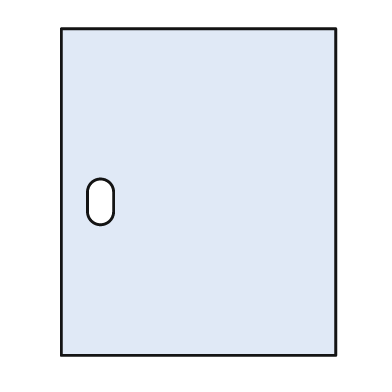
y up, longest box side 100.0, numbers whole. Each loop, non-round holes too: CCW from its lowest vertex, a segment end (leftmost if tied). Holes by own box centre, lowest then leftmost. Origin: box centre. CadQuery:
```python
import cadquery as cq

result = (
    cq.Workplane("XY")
    .moveTo(-42.0, -50.0)
    .lineTo(42.0, -50.0)
    .lineTo(42.0, 50.0)
    .lineTo(-42.0, 50.0)
    .close()
    .moveTo(-34.0, -6.0)
    .threePointArc((-30.0, -10.0), (-26.0, -6.0))
    .lineTo(-26.0, 0.0)
    .threePointArc((-30.0, 4.0), (-34.0, 0.0))
    .close()
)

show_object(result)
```